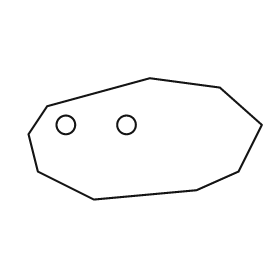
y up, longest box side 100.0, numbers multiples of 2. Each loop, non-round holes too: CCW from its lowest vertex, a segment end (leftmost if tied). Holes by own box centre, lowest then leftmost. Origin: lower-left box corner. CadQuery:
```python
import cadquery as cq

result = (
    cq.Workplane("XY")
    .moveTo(28.0, 0.0)
    .lineTo(72.0, 4.0)
    .lineTo(90.0, 12.0)
    .lineTo(100.0, 32.0)
    .lineTo(82.0, 48.0)
    .lineTo(52.0, 52.0)
    .lineTo(8.0, 40.0)
    .lineTo(0.0, 28.0)
    .lineTo(4.0, 12.0)
    .close()
    .moveTo(16.0, 32.0)
    .circle(4.0)
    .moveTo(42.0, 32.0)
    .circle(4.0)
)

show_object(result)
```